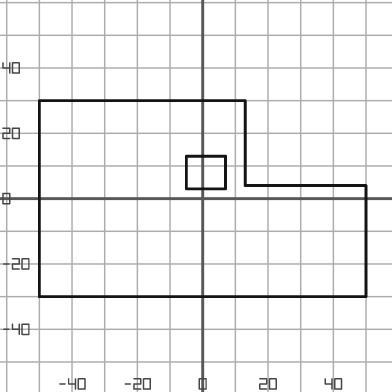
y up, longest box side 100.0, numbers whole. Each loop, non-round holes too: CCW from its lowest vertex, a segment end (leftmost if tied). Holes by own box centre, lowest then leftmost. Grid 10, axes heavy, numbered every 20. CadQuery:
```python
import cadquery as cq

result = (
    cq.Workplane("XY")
    .moveTo(-50.0, -30.0)
    .lineTo(50.0, -30.0)
    .lineTo(50.0, 4.0)
    .lineTo(13.0, 4.0)
    .lineTo(13.0, 30.0)
    .lineTo(-50.0, 30.0)
    .close()
    .moveTo(-5.0, 3.0)
    .lineTo(7.0, 3.0)
    .lineTo(7.0, 13.0)
    .lineTo(-5.0, 13.0)
    .close()
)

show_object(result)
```